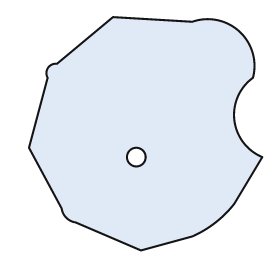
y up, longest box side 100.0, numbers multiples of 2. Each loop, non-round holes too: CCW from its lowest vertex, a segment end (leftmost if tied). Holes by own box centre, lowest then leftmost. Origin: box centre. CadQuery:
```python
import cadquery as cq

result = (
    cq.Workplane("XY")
    .moveTo(-2.0, -50.0)
    .lineTo(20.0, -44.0)
    .threePointArc((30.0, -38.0), (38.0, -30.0))
    .lineTo(50.0, -10.0)
    .threePointArc((38.0, 6.0), (46.0, 24.0))
    .threePointArc((40.0, 44.0), (20.0, 48.0))
    .lineTo(-14.0, 50.0)
    .lineTo(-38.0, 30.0)
    .threePointArc((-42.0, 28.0), (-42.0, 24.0))
    .lineTo(-50.0, -6.0)
    .lineTo(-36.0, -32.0)
    .threePointArc((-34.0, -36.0), (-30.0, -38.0))
    .close()
    .moveTo(-4.0, -10.0)
    .circle(4.0)
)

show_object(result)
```